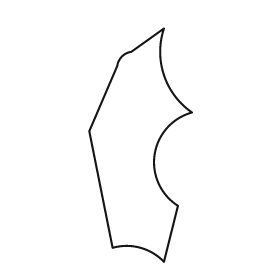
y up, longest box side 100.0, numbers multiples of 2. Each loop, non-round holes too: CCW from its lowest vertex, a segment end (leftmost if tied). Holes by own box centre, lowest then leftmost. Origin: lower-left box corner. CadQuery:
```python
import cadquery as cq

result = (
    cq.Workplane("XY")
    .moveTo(32.0, 0.0)
    .lineTo(38.0, 24.0)
    .threePointArc((28.0, 46.0), (44.0, 64.0))
    .threePointArc((32.0, 80.0), (32.0, 100.0))
    .lineTo(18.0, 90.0)
    .threePointArc((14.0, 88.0), (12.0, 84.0))
    .lineTo(0.0, 56.0)
    .lineTo(10.0, 6.0)
    .threePointArc((22.0, 6.0), (32.0, 0.0))
    .close()
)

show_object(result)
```